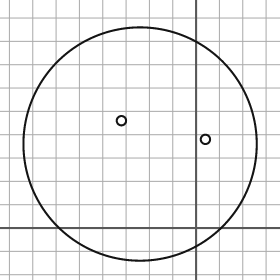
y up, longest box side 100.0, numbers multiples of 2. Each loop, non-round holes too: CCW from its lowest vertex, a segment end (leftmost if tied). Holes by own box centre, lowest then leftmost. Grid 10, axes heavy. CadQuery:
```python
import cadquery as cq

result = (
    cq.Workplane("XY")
    .moveTo(-24.0, 36.0)
    .circle(50.0)
    .moveTo(4.0, 38.0)
    .circle(2.0)
    .moveTo(-32.0, 46.0)
    .circle(2.0)
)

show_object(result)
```